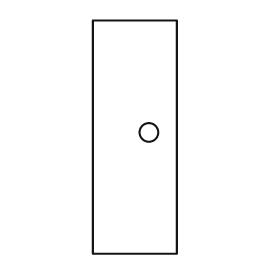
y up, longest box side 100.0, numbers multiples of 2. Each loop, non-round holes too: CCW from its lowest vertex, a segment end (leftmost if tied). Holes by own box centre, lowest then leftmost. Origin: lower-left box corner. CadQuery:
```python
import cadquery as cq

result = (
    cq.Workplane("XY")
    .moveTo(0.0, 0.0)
    .lineTo(36.0, 0.0)
    .lineTo(36.0, 100.0)
    .lineTo(0.0, 100.0)
    .close()
    .moveTo(24.0, 52.0)
    .circle(4.0)
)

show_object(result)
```